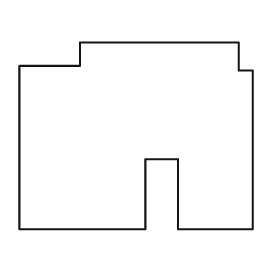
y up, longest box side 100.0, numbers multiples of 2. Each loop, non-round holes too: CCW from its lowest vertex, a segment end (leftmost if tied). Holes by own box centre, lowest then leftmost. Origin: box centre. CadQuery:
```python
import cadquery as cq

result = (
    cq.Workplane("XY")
    .moveTo(-50.0, -40.0)
    .lineTo(4.0, -40.0)
    .lineTo(4.0, -10.0)
    .lineTo(18.0, -10.0)
    .lineTo(18.0, -40.0)
    .lineTo(50.0, -40.0)
    .lineTo(50.0, 28.0)
    .lineTo(44.0, 28.0)
    .lineTo(44.0, 40.0)
    .lineTo(-24.0, 40.0)
    .lineTo(-24.0, 30.0)
    .lineTo(-50.0, 30.0)
    .close()
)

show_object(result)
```